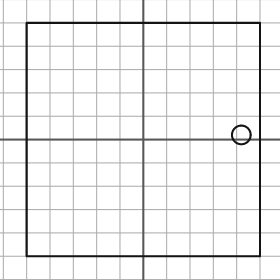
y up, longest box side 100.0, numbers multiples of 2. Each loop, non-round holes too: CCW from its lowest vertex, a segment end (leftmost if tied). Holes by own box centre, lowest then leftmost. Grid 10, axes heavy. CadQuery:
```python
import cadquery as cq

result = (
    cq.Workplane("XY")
    .moveTo(-50.0, -50.0)
    .lineTo(50.0, -50.0)
    .lineTo(50.0, 50.0)
    .lineTo(-50.0, 50.0)
    .close()
    .moveTo(42.0, 2.0)
    .circle(4.0)
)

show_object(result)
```